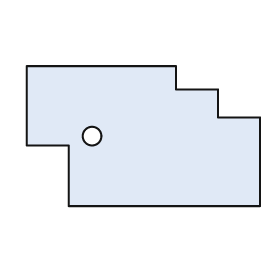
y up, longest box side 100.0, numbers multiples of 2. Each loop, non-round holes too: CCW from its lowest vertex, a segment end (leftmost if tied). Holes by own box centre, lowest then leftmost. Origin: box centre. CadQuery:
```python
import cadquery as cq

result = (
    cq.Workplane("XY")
    .moveTo(-32.0, -30.0)
    .lineTo(50.0, -30.0)
    .lineTo(50.0, 8.0)
    .lineTo(32.0, 8.0)
    .lineTo(32.0, 20.0)
    .lineTo(14.0, 20.0)
    .lineTo(14.0, 30.0)
    .lineTo(-50.0, 30.0)
    .lineTo(-50.0, -4.0)
    .lineTo(-32.0, -4.0)
    .close()
    .moveTo(-22.0, 0.0)
    .circle(4.0)
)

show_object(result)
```